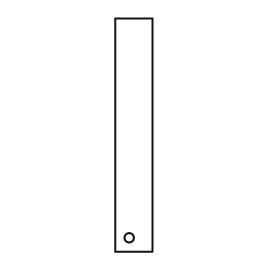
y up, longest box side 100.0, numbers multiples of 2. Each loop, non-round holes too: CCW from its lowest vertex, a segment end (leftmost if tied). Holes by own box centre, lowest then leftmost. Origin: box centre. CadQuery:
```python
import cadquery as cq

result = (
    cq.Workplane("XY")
    .moveTo(-8.0, -50.0)
    .lineTo(8.0, -50.0)
    .lineTo(8.0, 50.0)
    .lineTo(-8.0, 50.0)
    .close()
    .moveTo(-2.0, -44.0)
    .circle(2.0)
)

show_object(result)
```